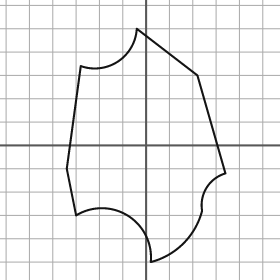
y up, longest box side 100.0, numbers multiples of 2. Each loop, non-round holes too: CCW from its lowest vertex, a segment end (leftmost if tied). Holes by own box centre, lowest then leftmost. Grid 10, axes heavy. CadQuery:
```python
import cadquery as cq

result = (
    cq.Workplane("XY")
    .moveTo(2.0, -50.0)
    .threePointArc((16.0, -42.0), (24.0, -28.0))
    .threePointArc((26.0, -18.0), (34.0, -12.0))
    .lineTo(22.0, 30.0)
    .lineTo(-4.0, 50.0)
    .threePointArc((-12.0, 36.0), (-28.0, 34.0))
    .lineTo(-34.0, -10.0)
    .lineTo(-30.0, -30.0)
    .threePointArc((-8.0, -30.0), (2.0, -50.0))
    .close()
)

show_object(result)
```